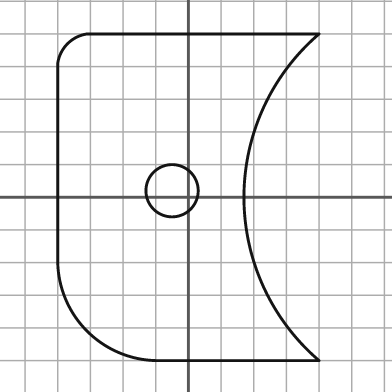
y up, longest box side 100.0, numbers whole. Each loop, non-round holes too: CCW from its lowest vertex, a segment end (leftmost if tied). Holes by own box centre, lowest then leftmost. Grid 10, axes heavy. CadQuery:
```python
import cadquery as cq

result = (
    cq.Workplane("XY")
    .moveTo(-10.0, -50.0)
    .lineTo(40.0, -50.0)
    .threePointArc((17.0, 0.0), (40.0, 50.0))
    .lineTo(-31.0, 50.0)
    .threePointArc((-37.0, 47.0), (-40.0, 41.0))
    .lineTo(-40.0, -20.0)
    .threePointArc((-31.0, -41.0), (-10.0, -50.0))
    .close()
    .moveTo(-5.0, 2.0)
    .circle(8.0)
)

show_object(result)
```